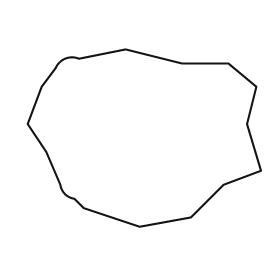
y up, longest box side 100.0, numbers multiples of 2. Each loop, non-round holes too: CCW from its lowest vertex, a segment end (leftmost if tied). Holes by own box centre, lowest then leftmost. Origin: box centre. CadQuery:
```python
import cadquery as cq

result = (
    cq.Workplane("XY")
    .moveTo(-2.0, -38.0)
    .lineTo(20.0, -34.0)
    .lineTo(34.0, -20.0)
    .lineTo(50.0, -14.0)
    .lineTo(44.0, 6.0)
    .lineTo(48.0, 22.0)
    .lineTo(36.0, 32.0)
    .lineTo(16.0, 32.0)
    .lineTo(-8.0, 38.0)
    .lineTo(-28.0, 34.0)
    .threePointArc((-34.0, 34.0), (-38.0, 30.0))
    .lineTo(-44.0, 22.0)
    .lineTo(-50.0, 6.0)
    .lineTo(-42.0, -6.0)
    .lineTo(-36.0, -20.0)
    .threePointArc((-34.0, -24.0), (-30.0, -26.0))
    .lineTo(-26.0, -30.0)
    .close()
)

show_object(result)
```